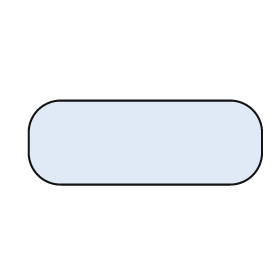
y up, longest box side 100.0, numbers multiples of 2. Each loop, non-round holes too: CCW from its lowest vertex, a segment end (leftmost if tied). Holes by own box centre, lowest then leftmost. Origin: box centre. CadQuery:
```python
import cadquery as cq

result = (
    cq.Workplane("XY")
    .moveTo(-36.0, -18.0)
    .lineTo(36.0, -18.0)
    .threePointArc((46.0, -14.0), (50.0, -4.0))
    .lineTo(50.0, 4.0)
    .threePointArc((46.0, 14.0), (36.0, 18.0))
    .lineTo(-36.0, 18.0)
    .threePointArc((-46.0, 14.0), (-50.0, 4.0))
    .lineTo(-50.0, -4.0)
    .threePointArc((-46.0, -14.0), (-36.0, -18.0))
    .close()
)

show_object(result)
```